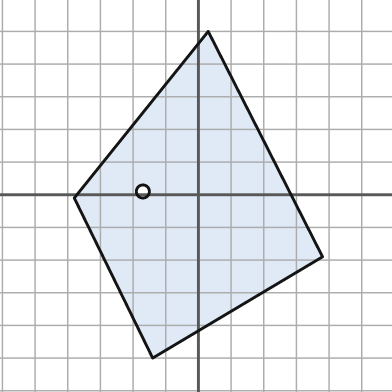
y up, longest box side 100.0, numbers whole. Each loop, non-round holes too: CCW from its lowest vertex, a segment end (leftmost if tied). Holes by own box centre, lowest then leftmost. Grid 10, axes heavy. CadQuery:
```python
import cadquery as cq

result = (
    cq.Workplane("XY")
    .moveTo(-14.0, -50.0)
    .lineTo(38.0, -19.0)
    .lineTo(3.0, 50.0)
    .lineTo(-38.0, -1.0)
    .close()
    .moveTo(-17.0, 1.0)
    .circle(2.0)
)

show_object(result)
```